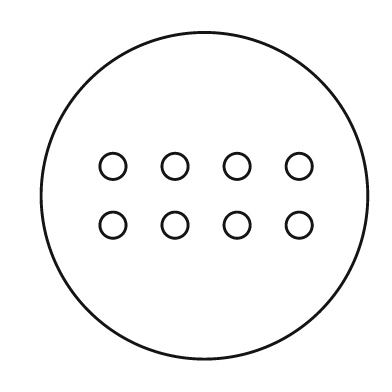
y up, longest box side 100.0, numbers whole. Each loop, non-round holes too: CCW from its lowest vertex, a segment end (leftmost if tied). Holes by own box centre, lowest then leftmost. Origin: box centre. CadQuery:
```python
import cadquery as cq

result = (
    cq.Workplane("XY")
    .moveTo(0.0, 0.0)
    .circle(50.0)
    .moveTo(-28.0, -9.0)
    .circle(4.0)
    .moveTo(-9.0, -9.0)
    .circle(4.0)
    .moveTo(10.0, -9.0)
    .circle(4.0)
    .moveTo(29.0, -9.0)
    .circle(4.0)
    .moveTo(-28.0, 9.0)
    .circle(4.0)
    .moveTo(-9.0, 9.0)
    .circle(4.0)
    .moveTo(10.0, 9.0)
    .circle(4.0)
    .moveTo(29.0, 9.0)
    .circle(4.0)
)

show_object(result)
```